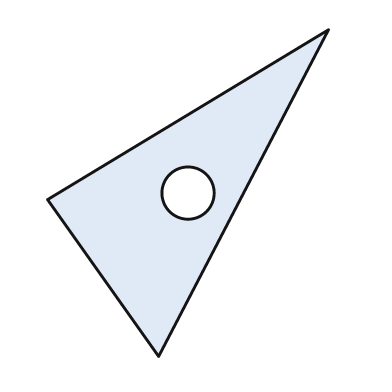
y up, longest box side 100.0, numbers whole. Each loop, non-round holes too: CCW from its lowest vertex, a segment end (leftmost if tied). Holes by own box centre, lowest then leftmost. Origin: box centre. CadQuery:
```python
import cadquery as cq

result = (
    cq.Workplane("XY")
    .moveTo(-9.0, -50.0)
    .lineTo(43.0, 50.0)
    .lineTo(-43.0, -2.0)
    .close()
    .moveTo(0.0, 0.0)
    .circle(8.0)
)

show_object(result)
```